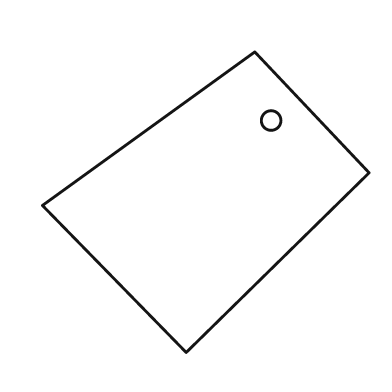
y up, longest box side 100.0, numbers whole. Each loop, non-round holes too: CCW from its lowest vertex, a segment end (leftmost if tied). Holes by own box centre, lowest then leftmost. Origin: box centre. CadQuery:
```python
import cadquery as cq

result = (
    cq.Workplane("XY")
    .moveTo(-6.0, -46.0)
    .lineTo(50.0, 9.0)
    .lineTo(15.0, 46.0)
    .lineTo(-50.0, -1.0)
    .close()
    .moveTo(20.0, 25.0)
    .circle(3.0)
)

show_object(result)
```